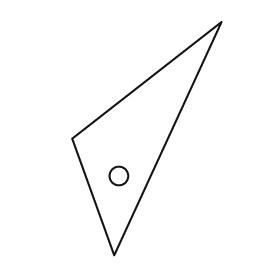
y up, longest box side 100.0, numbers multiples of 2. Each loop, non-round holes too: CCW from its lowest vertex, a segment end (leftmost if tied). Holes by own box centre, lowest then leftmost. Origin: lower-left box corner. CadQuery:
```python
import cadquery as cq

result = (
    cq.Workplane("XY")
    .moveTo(18.0, 0.0)
    .lineTo(64.0, 100.0)
    .lineTo(0.0, 50.0)
    .close()
    .moveTo(20.0, 34.0)
    .circle(4.0)
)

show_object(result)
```